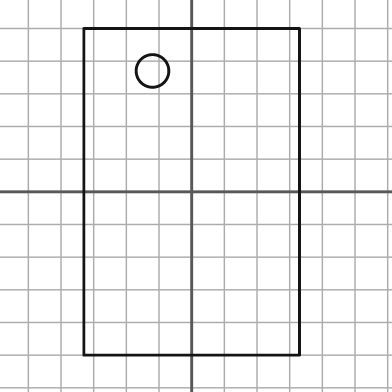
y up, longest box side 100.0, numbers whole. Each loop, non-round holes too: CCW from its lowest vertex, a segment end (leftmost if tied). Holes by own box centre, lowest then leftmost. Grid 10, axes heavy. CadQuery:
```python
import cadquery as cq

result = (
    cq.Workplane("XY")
    .moveTo(-33.0, -50.0)
    .lineTo(33.0, -50.0)
    .lineTo(33.0, 50.0)
    .lineTo(-33.0, 50.0)
    .close()
    .moveTo(-12.0, 37.0)
    .circle(5.0)
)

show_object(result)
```